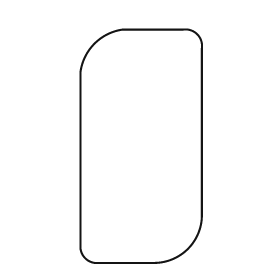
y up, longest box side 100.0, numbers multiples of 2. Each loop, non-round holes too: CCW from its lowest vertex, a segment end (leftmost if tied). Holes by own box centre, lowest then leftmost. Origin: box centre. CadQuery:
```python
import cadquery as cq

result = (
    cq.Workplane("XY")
    .moveTo(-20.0, -50.0)
    .lineTo(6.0, -50.0)
    .threePointArc((20.0, -44.0), (26.0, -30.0))
    .lineTo(26.0, 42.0)
    .threePointArc((24.0, 48.0), (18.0, 50.0))
    .lineTo(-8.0, 50.0)
    .threePointArc((-20.0, 44.0), (-26.0, 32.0))
    .lineTo(-26.0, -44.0)
    .threePointArc((-24.0, -48.0), (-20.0, -50.0))
    .close()
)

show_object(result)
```